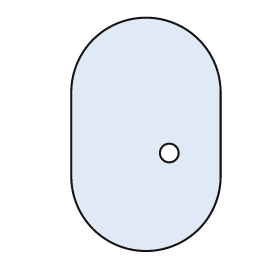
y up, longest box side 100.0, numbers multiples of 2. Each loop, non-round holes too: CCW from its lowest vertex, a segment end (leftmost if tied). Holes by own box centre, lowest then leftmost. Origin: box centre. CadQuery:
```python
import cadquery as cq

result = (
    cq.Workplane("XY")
    .moveTo(-32.0, -18.0)
    .threePointArc((0.0, -50.0), (32.0, -18.0))
    .lineTo(32.0, 18.0)
    .threePointArc((0.0, 50.0), (-32.0, 18.0))
    .close()
    .moveTo(10.0, -8.0)
    .circle(4.0)
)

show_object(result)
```